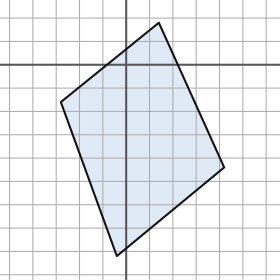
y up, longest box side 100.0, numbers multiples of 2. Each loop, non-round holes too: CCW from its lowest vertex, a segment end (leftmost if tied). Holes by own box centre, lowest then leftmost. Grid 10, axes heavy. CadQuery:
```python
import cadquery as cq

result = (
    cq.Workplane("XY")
    .moveTo(-4.0, -82.0)
    .lineTo(42.0, -44.0)
    .lineTo(14.0, 18.0)
    .lineTo(-28.0, -16.0)
    .close()
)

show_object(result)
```